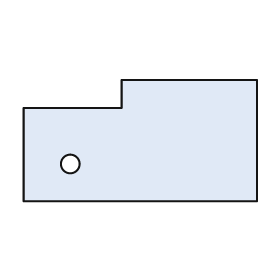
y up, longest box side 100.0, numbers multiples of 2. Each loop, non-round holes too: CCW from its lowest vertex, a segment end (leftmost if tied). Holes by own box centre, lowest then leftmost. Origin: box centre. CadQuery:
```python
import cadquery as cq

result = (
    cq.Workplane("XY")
    .moveTo(-50.0, -26.0)
    .lineTo(50.0, -26.0)
    .lineTo(50.0, 26.0)
    .lineTo(-8.0, 26.0)
    .lineTo(-8.0, 14.0)
    .lineTo(-50.0, 14.0)
    .close()
    .moveTo(-30.0, -10.0)
    .circle(4.0)
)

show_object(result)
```